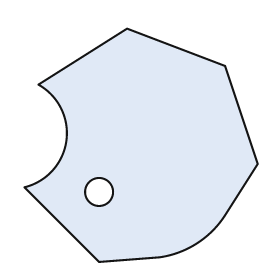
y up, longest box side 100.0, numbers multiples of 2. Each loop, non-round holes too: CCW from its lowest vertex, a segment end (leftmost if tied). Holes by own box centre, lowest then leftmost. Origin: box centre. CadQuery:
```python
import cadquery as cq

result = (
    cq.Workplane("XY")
    .moveTo(-18.0, -50.0)
    .lineTo(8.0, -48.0)
    .threePointArc((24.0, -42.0), (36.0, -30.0))
    .lineTo(50.0, -8.0)
    .lineTo(36.0, 34.0)
    .lineTo(-6.0, 50.0)
    .lineTo(-44.0, 26.0)
    .threePointArc((-32.0, 2.0), (-50.0, -18.0))
    .close()
    .moveTo(-18.0, -20.0)
    .circle(6.0)
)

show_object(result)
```